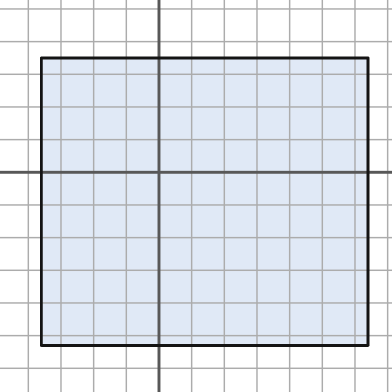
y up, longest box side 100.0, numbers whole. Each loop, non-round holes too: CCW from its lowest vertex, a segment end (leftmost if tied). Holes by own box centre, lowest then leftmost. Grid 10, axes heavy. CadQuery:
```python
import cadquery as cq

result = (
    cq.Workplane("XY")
    .moveTo(-36.0, -53.0)
    .lineTo(64.0, -53.0)
    .lineTo(64.0, 35.0)
    .lineTo(-36.0, 35.0)
    .close()
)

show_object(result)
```